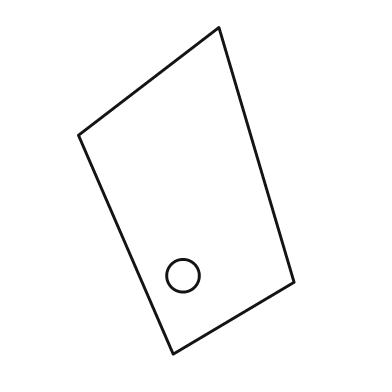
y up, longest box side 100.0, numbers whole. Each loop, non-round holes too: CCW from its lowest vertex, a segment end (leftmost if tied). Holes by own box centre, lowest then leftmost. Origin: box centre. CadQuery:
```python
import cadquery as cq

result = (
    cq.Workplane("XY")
    .moveTo(-4.0, -50.0)
    .lineTo(33.0, -28.0)
    .lineTo(10.0, 50.0)
    .lineTo(-33.0, 17.0)
    .close()
    .moveTo(-1.0, -26.0)
    .circle(5.0)
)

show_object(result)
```